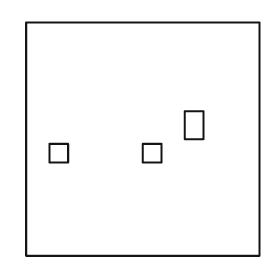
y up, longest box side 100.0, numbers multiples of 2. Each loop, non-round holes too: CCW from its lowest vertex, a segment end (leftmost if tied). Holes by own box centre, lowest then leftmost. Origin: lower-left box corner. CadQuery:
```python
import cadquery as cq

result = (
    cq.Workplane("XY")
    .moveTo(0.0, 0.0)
    .lineTo(100.0, 0.0)
    .lineTo(100.0, 100.0)
    .lineTo(0.0, 100.0)
    .close()
    .moveTo(10.0, 40.0)
    .lineTo(18.0, 40.0)
    .lineTo(18.0, 48.0)
    .lineTo(10.0, 48.0)
    .close()
    .moveTo(50.0, 40.0)
    .lineTo(58.0, 40.0)
    .lineTo(58.0, 48.0)
    .lineTo(50.0, 48.0)
    .close()
    .moveTo(68.0, 50.0)
    .lineTo(76.0, 50.0)
    .lineTo(76.0, 62.0)
    .lineTo(68.0, 62.0)
    .close()
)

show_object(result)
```